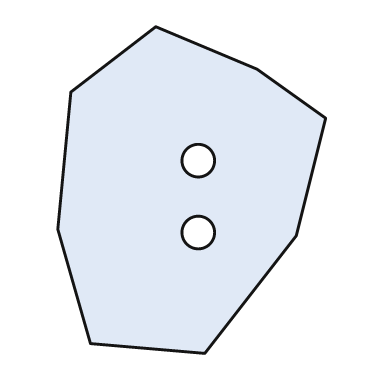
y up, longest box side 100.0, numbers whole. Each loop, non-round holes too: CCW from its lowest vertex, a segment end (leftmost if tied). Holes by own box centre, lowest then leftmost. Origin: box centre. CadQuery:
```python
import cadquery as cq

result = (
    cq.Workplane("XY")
    .moveTo(4.0, -50.0)
    .lineTo(32.0, -14.0)
    .lineTo(41.0, 22.0)
    .lineTo(20.0, 37.0)
    .lineTo(-11.0, 50.0)
    .lineTo(-37.0, 30.0)
    .lineTo(-41.0, -12.0)
    .lineTo(-31.0, -47.0)
    .close()
    .moveTo(2.0, -13.0)
    .circle(5.0)
    .moveTo(2.0, 9.0)
    .circle(5.0)
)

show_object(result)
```